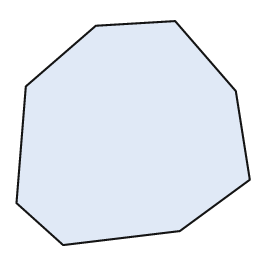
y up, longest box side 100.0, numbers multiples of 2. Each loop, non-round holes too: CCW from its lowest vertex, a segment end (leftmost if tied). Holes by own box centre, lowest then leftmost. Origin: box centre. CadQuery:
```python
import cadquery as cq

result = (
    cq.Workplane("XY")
    .moveTo(-30.0, -48.0)
    .lineTo(20.0, -42.0)
    .lineTo(50.0, -20.0)
    .lineTo(44.0, 18.0)
    .lineTo(18.0, 48.0)
    .lineTo(-16.0, 46.0)
    .lineTo(-46.0, 20.0)
    .lineTo(-50.0, -30.0)
    .close()
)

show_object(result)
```